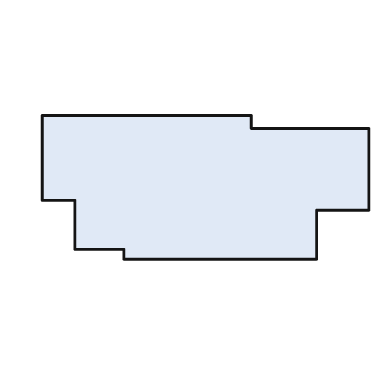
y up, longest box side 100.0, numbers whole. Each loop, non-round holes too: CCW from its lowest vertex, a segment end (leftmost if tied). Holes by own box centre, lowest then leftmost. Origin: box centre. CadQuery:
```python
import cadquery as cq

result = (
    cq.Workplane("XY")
    .moveTo(-25.0, -22.0)
    .lineTo(34.0, -22.0)
    .lineTo(34.0, -7.0)
    .lineTo(50.0, -7.0)
    .lineTo(50.0, 18.0)
    .lineTo(14.0, 18.0)
    .lineTo(14.0, 22.0)
    .lineTo(-50.0, 22.0)
    .lineTo(-50.0, -4.0)
    .lineTo(-40.0, -4.0)
    .lineTo(-40.0, -19.0)
    .lineTo(-25.0, -19.0)
    .close()
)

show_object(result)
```